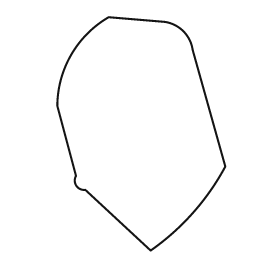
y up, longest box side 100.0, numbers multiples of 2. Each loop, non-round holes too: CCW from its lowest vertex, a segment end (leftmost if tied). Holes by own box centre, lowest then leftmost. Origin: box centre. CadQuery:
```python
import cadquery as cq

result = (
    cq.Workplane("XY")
    .moveTo(4.0, -50.0)
    .threePointArc((22.0, -34.0), (36.0, -14.0))
    .lineTo(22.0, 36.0)
    .threePointArc((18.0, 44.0), (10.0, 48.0))
    .lineTo(-14.0, 50.0)
    .threePointArc((-30.0, 34.0), (-36.0, 12.0))
    .lineTo(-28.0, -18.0)
    .threePointArc((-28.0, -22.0), (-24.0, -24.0))
    .close()
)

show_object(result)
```